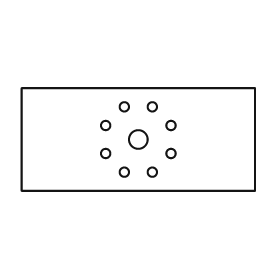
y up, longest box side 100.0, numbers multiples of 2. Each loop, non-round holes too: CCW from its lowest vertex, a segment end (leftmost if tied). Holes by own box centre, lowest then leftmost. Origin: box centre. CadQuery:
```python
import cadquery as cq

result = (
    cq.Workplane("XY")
    .moveTo(-50.0, -22.0)
    .lineTo(50.0, -22.0)
    .lineTo(50.0, 22.0)
    .lineTo(-50.0, 22.0)
    .close()
    .moveTo(-6.0, -14.0)
    .circle(2.0)
    .moveTo(6.0, -14.0)
    .circle(2.0)
    .moveTo(-14.0, -6.0)
    .circle(2.0)
    .moveTo(14.0, -6.0)
    .circle(2.0)
    .moveTo(0.0, 0.0)
    .circle(4.0)
    .moveTo(-14.0, 6.0)
    .circle(2.0)
    .moveTo(14.0, 6.0)
    .circle(2.0)
    .moveTo(-6.0, 14.0)
    .circle(2.0)
    .moveTo(6.0, 14.0)
    .circle(2.0)
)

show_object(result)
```